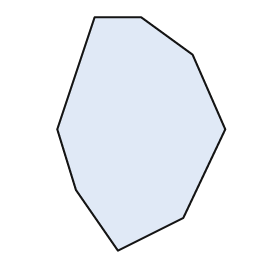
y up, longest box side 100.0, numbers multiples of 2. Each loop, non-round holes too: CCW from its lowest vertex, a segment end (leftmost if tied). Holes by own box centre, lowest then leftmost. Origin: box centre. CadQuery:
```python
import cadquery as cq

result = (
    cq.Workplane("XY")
    .moveTo(-10.0, -50.0)
    .lineTo(18.0, -36.0)
    .lineTo(36.0, 2.0)
    .lineTo(22.0, 34.0)
    .lineTo(0.0, 50.0)
    .lineTo(-20.0, 50.0)
    .lineTo(-36.0, 2.0)
    .lineTo(-28.0, -24.0)
    .close()
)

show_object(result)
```